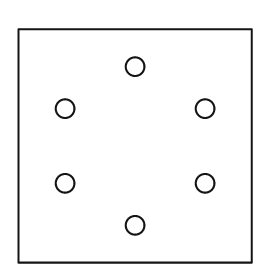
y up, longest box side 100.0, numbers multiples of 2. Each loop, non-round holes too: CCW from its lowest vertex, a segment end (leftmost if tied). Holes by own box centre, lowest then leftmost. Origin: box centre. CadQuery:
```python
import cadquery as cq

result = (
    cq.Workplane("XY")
    .moveTo(-50.0, -50.0)
    .lineTo(50.0, -50.0)
    .lineTo(50.0, 50.0)
    .lineTo(-50.0, 50.0)
    .close()
    .moveTo(0.0, -34.0)
    .circle(4.0)
    .moveTo(-30.0, -16.0)
    .circle(4.0)
    .moveTo(30.0, -16.0)
    .circle(4.0)
    .moveTo(-30.0, 16.0)
    .circle(4.0)
    .moveTo(30.0, 16.0)
    .circle(4.0)
    .moveTo(0.0, 34.0)
    .circle(4.0)
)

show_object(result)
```